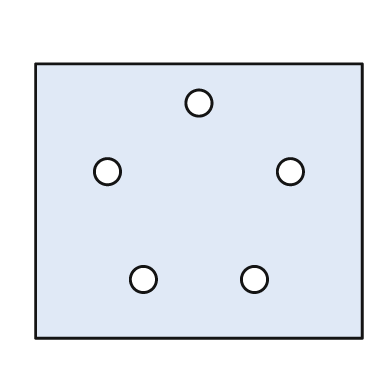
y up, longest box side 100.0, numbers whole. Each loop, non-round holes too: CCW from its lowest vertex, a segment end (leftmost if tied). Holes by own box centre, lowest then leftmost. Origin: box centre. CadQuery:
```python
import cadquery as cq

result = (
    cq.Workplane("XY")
    .moveTo(-50.0, -42.0)
    .lineTo(50.0, -42.0)
    .lineTo(50.0, 42.0)
    .lineTo(-50.0, 42.0)
    .close()
    .moveTo(-17.0, -24.0)
    .circle(4.0)
    .moveTo(17.0, -24.0)
    .circle(4.0)
    .moveTo(-28.0, 9.0)
    .circle(4.0)
    .moveTo(28.0, 9.0)
    .circle(4.0)
    .moveTo(0.0, 30.0)
    .circle(4.0)
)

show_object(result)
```